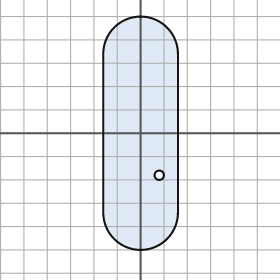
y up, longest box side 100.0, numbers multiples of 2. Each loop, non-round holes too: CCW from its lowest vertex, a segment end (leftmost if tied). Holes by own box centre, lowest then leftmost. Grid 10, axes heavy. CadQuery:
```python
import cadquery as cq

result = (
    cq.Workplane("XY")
    .moveTo(-16.0, -34.0)
    .threePointArc((0.0, -50.0), (16.0, -34.0))
    .lineTo(16.0, 34.0)
    .threePointArc((0.0, 50.0), (-16.0, 34.0))
    .close()
    .moveTo(8.0, -18.0)
    .circle(2.0)
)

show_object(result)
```